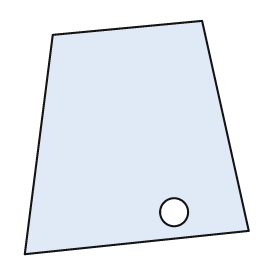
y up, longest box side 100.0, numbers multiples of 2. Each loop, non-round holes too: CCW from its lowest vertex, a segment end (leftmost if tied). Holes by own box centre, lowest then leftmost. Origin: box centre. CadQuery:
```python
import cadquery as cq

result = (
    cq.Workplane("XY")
    .moveTo(-48.0, -50.0)
    .lineTo(48.0, -40.0)
    .lineTo(28.0, 50.0)
    .lineTo(-36.0, 44.0)
    .close()
    .moveTo(16.0, -32.0)
    .circle(6.0)
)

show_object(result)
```